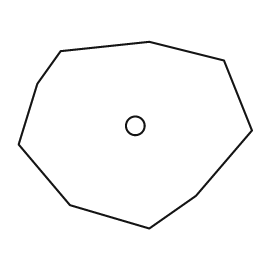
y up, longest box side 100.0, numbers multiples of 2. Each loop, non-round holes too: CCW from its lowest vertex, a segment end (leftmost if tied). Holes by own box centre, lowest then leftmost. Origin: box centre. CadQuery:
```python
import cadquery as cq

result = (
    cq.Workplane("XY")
    .moveTo(6.0, -40.0)
    .lineTo(26.0, -26.0)
    .lineTo(50.0, 2.0)
    .lineTo(38.0, 32.0)
    .lineTo(6.0, 40.0)
    .lineTo(-32.0, 36.0)
    .lineTo(-42.0, 22.0)
    .lineTo(-50.0, -4.0)
    .lineTo(-28.0, -30.0)
    .close()
    .moveTo(0.0, 4.0)
    .circle(4.0)
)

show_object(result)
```